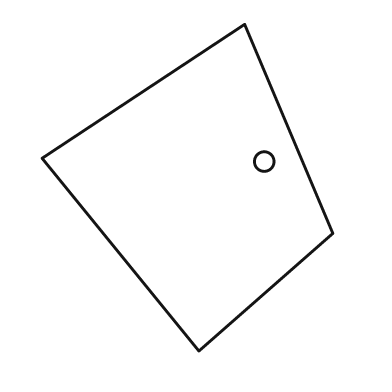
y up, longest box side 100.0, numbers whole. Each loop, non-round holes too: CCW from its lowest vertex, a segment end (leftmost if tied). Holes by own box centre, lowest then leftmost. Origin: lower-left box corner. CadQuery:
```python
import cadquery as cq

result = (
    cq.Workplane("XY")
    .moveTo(48.0, 0.0)
    .lineTo(89.0, 36.0)
    .lineTo(62.0, 100.0)
    .lineTo(0.0, 59.0)
    .close()
    .moveTo(68.0, 58.0)
    .circle(3.0)
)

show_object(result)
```